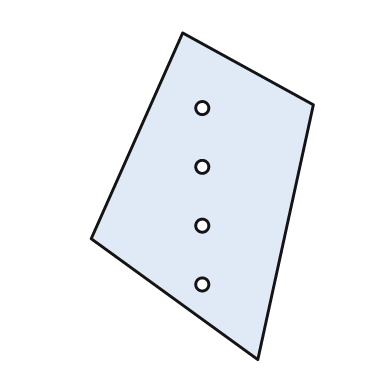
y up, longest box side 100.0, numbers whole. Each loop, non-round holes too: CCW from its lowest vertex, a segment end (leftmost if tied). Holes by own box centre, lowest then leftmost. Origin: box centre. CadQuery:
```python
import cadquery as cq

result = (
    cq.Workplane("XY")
    .moveTo(17.0, -50.0)
    .lineTo(34.0, 28.0)
    .lineTo(-6.0, 50.0)
    .lineTo(-34.0, -13.0)
    .close()
    .moveTo(0.0, -27.0)
    .circle(2.0)
    .moveTo(0.0, -9.0)
    .circle(2.0)
    .moveTo(0.0, 9.0)
    .circle(2.0)
    .moveTo(0.0, 27.0)
    .circle(2.0)
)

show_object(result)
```